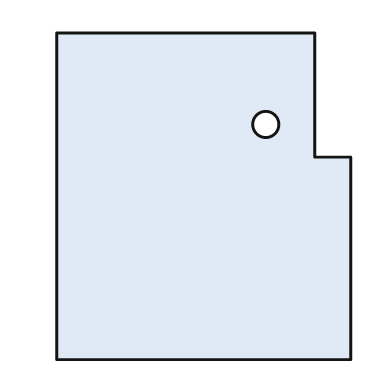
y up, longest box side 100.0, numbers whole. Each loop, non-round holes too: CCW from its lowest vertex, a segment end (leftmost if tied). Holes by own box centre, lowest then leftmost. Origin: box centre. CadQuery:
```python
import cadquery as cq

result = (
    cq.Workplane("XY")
    .moveTo(-45.0, -50.0)
    .lineTo(45.0, -50.0)
    .lineTo(45.0, 12.0)
    .lineTo(34.0, 12.0)
    .lineTo(34.0, 50.0)
    .lineTo(-45.0, 50.0)
    .close()
    .moveTo(19.0, 22.0)
    .circle(4.0)
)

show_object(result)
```